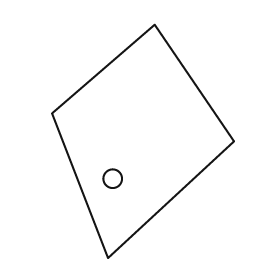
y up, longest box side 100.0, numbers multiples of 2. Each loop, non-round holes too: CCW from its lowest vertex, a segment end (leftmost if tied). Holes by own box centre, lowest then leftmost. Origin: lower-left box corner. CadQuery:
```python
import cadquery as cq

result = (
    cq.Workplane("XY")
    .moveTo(24.0, 0.0)
    .lineTo(78.0, 50.0)
    .lineTo(44.0, 100.0)
    .lineTo(0.0, 62.0)
    .close()
    .moveTo(26.0, 34.0)
    .circle(4.0)
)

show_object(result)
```